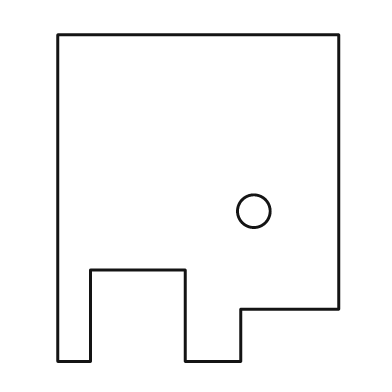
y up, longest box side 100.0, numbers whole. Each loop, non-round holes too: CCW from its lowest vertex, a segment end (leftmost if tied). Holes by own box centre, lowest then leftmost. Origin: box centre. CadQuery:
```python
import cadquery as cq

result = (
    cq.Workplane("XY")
    .moveTo(-43.0, -50.0)
    .lineTo(-33.0, -50.0)
    .lineTo(-33.0, -22.0)
    .lineTo(-4.0, -22.0)
    .lineTo(-4.0, -50.0)
    .lineTo(13.0, -50.0)
    .lineTo(13.0, -34.0)
    .lineTo(43.0, -34.0)
    .lineTo(43.0, 50.0)
    .lineTo(-43.0, 50.0)
    .close()
    .moveTo(17.0, -4.0)
    .circle(5.0)
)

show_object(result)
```